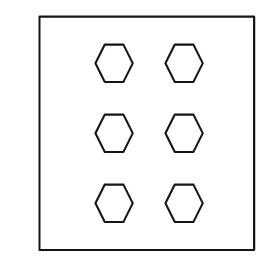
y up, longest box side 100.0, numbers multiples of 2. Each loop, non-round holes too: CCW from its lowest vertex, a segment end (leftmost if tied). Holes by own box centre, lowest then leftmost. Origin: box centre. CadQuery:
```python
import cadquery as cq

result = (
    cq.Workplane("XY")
    .moveTo(-46.0, -50.0)
    .lineTo(46.0, -50.0)
    .lineTo(46.0, 50.0)
    .lineTo(-46.0, 50.0)
    .close()
    .moveTo(-18.0, -38.0)
    .lineTo(-10.0, -38.0)
    .lineTo(-6.0, -30.0)
    .lineTo(-10.0, -22.0)
    .lineTo(-18.0, -22.0)
    .lineTo(-22.0, -30.0)
    .close()
    .moveTo(12.0, -38.0)
    .lineTo(20.0, -38.0)
    .lineTo(24.0, -30.0)
    .lineTo(20.0, -22.0)
    .lineTo(12.0, -22.0)
    .lineTo(8.0, -30.0)
    .close()
    .moveTo(-18.0, -8.0)
    .lineTo(-10.0, -8.0)
    .lineTo(-6.0, 0.0)
    .lineTo(-10.0, 8.0)
    .lineTo(-18.0, 8.0)
    .lineTo(-22.0, 0.0)
    .close()
    .moveTo(12.0, -8.0)
    .lineTo(20.0, -8.0)
    .lineTo(24.0, 0.0)
    .lineTo(20.0, 8.0)
    .lineTo(12.0, 8.0)
    .lineTo(8.0, 0.0)
    .close()
    .moveTo(-18.0, 22.0)
    .lineTo(-10.0, 22.0)
    .lineTo(-6.0, 30.0)
    .lineTo(-10.0, 38.0)
    .lineTo(-18.0, 38.0)
    .lineTo(-22.0, 30.0)
    .close()
    .moveTo(12.0, 22.0)
    .lineTo(20.0, 22.0)
    .lineTo(24.0, 30.0)
    .lineTo(20.0, 38.0)
    .lineTo(12.0, 38.0)
    .lineTo(8.0, 30.0)
    .close()
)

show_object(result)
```